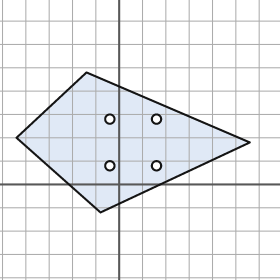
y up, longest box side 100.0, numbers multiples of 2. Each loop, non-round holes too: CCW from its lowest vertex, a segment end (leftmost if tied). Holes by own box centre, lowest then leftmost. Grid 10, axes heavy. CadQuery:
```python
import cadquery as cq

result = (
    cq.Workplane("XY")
    .moveTo(-8.0, -12.0)
    .lineTo(56.0, 18.0)
    .lineTo(-14.0, 48.0)
    .lineTo(-44.0, 20.0)
    .close()
    .moveTo(-4.0, 8.0)
    .circle(2.0)
    .moveTo(16.0, 8.0)
    .circle(2.0)
    .moveTo(-4.0, 28.0)
    .circle(2.0)
    .moveTo(16.0, 28.0)
    .circle(2.0)
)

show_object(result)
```